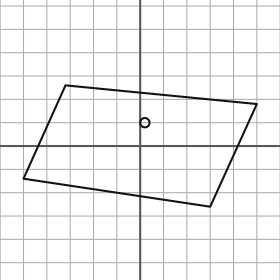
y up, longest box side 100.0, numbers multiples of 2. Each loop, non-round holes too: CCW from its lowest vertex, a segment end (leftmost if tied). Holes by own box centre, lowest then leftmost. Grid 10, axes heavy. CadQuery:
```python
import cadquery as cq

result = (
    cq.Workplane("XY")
    .moveTo(30.0, -26.0)
    .lineTo(50.0, 18.0)
    .lineTo(-32.0, 26.0)
    .lineTo(-50.0, -14.0)
    .close()
    .moveTo(2.0, 10.0)
    .circle(2.0)
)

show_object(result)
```